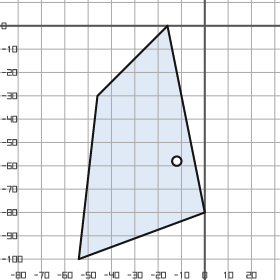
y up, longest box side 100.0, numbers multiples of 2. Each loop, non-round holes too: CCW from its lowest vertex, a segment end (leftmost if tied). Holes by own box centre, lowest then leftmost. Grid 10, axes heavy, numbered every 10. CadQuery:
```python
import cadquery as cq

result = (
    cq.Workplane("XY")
    .moveTo(-54.0, -100.0)
    .lineTo(0.0, -80.0)
    .lineTo(-16.0, 0.0)
    .lineTo(-46.0, -30.0)
    .close()
    .moveTo(-12.0, -58.0)
    .circle(2.0)
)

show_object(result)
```